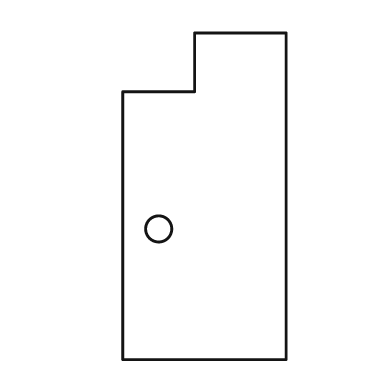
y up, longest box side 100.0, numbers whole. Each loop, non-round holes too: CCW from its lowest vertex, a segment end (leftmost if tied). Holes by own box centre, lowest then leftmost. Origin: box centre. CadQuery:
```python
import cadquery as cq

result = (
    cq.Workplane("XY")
    .moveTo(-25.0, -50.0)
    .lineTo(25.0, -50.0)
    .lineTo(25.0, 50.0)
    .lineTo(-3.0, 50.0)
    .lineTo(-3.0, 32.0)
    .lineTo(-25.0, 32.0)
    .close()
    .moveTo(-14.0, -10.0)
    .circle(4.0)
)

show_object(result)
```